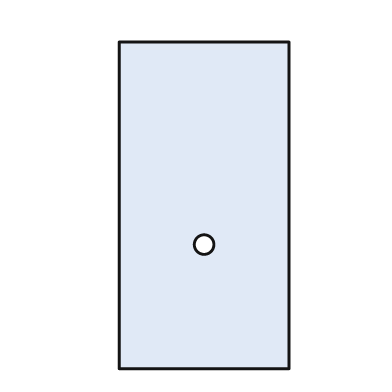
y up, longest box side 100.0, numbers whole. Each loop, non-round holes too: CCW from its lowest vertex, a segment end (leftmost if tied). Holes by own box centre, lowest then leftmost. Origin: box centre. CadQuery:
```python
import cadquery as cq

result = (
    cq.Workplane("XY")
    .moveTo(-26.0, -50.0)
    .lineTo(26.0, -50.0)
    .lineTo(26.0, 50.0)
    .lineTo(-26.0, 50.0)
    .close()
    .moveTo(0.0, -12.0)
    .circle(3.0)
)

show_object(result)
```